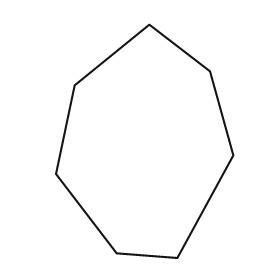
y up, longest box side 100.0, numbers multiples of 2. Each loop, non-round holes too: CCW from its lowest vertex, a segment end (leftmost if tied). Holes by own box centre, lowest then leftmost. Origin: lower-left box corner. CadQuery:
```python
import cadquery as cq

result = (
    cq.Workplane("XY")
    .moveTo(52.0, 0.0)
    .lineTo(76.0, 44.0)
    .lineTo(66.0, 80.0)
    .lineTo(40.0, 100.0)
    .lineTo(8.0, 74.0)
    .lineTo(0.0, 36.0)
    .lineTo(26.0, 2.0)
    .close()
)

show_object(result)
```